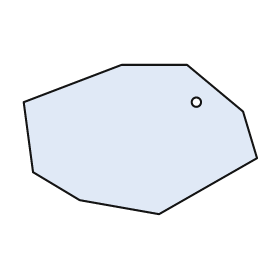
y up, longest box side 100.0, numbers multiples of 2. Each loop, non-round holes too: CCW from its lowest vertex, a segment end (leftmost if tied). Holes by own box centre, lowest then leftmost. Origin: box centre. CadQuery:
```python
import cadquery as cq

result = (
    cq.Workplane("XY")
    .moveTo(8.0, -32.0)
    .lineTo(50.0, -8.0)
    .lineTo(44.0, 12.0)
    .lineTo(20.0, 32.0)
    .lineTo(-8.0, 32.0)
    .lineTo(-50.0, 16.0)
    .lineTo(-46.0, -14.0)
    .lineTo(-26.0, -26.0)
    .close()
    .moveTo(24.0, 16.0)
    .circle(2.0)
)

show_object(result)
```